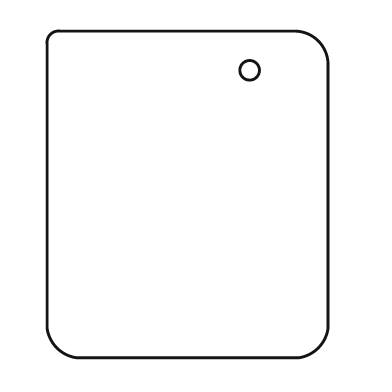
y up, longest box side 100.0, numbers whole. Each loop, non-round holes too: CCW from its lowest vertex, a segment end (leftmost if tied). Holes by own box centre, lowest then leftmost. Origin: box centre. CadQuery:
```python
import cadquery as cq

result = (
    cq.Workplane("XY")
    .moveTo(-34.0, -50.0)
    .lineTo(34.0, -50.0)
    .threePointArc((40.0, -47.0), (43.0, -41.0))
    .lineTo(43.0, 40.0)
    .threePointArc((40.0, 47.0), (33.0, 50.0))
    .lineTo(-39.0, 50.0)
    .threePointArc((-42.0, 49.0), (-43.0, 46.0))
    .lineTo(-43.0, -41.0)
    .threePointArc((-40.0, -47.0), (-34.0, -50.0))
    .close()
    .moveTo(19.0, 38.0)
    .circle(3.0)
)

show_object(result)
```